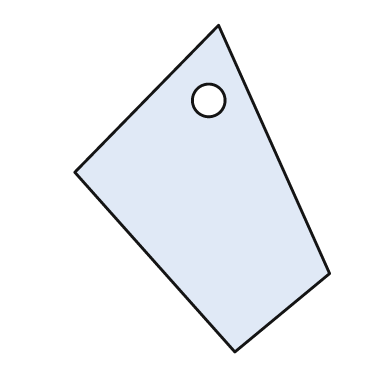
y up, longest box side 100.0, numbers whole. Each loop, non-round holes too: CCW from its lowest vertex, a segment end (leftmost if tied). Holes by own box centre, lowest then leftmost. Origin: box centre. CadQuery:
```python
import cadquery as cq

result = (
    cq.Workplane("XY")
    .moveTo(10.0, -50.0)
    .lineTo(39.0, -26.0)
    .lineTo(5.0, 50.0)
    .lineTo(-39.0, 5.0)
    .close()
    .moveTo(2.0, 27.0)
    .circle(5.0)
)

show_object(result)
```